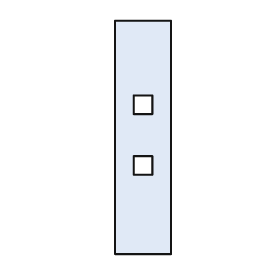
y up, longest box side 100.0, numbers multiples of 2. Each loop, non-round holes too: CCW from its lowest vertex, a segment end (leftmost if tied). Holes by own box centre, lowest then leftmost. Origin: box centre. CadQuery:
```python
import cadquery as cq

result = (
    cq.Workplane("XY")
    .moveTo(-12.0, -50.0)
    .lineTo(12.0, -50.0)
    .lineTo(12.0, 50.0)
    .lineTo(-12.0, 50.0)
    .close()
    .moveTo(-4.0, -16.0)
    .lineTo(4.0, -16.0)
    .lineTo(4.0, -8.0)
    .lineTo(-4.0, -8.0)
    .close()
    .moveTo(-4.0, 10.0)
    .lineTo(4.0, 10.0)
    .lineTo(4.0, 18.0)
    .lineTo(-4.0, 18.0)
    .close()
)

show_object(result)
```